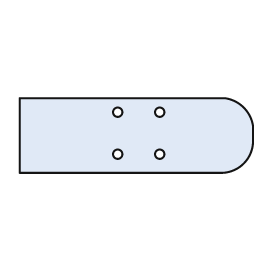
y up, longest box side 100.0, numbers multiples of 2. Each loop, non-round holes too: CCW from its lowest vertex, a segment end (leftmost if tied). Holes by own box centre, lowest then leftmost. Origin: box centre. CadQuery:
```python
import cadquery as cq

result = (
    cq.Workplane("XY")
    .moveTo(-50.0, -16.0)
    .lineTo(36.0, -16.0)
    .threePointArc((46.0, -12.0), (50.0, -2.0))
    .lineTo(50.0, 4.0)
    .threePointArc((46.0, 12.0), (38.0, 16.0))
    .lineTo(-50.0, 16.0)
    .close()
    .moveTo(-8.0, -8.0)
    .circle(2.0)
    .moveTo(10.0, -8.0)
    .circle(2.0)
    .moveTo(-8.0, 10.0)
    .circle(2.0)
    .moveTo(10.0, 10.0)
    .circle(2.0)
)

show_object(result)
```